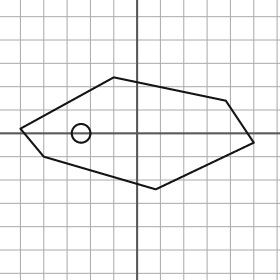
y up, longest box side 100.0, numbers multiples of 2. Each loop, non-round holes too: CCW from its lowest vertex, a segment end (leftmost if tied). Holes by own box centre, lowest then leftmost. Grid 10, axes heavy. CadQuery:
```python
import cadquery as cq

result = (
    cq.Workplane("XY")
    .moveTo(8.0, -24.0)
    .lineTo(50.0, -4.0)
    .lineTo(38.0, 14.0)
    .lineTo(-10.0, 24.0)
    .lineTo(-50.0, 2.0)
    .lineTo(-40.0, -10.0)
    .close()
    .moveTo(-24.0, 0.0)
    .circle(4.0)
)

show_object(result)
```